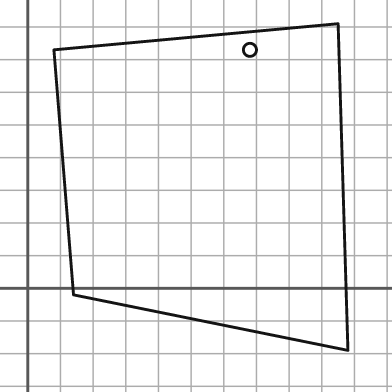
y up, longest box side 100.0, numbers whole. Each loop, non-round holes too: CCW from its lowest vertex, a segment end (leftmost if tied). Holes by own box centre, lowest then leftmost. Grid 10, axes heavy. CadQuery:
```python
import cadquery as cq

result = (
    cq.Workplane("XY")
    .moveTo(98.0, -19.0)
    .lineTo(95.0, 81.0)
    .lineTo(8.0, 73.0)
    .lineTo(14.0, -2.0)
    .close()
    .moveTo(68.0, 73.0)
    .circle(2.0)
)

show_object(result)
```